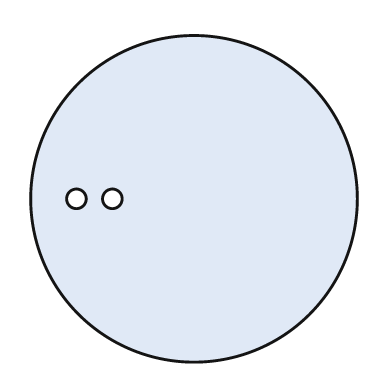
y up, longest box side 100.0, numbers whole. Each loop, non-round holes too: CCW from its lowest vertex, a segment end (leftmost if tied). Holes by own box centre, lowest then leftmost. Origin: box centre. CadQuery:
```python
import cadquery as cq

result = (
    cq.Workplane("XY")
    .moveTo(0.0, 0.0)
    .circle(50.0)
    .moveTo(-36.0, 0.0)
    .circle(3.0)
    .moveTo(-25.0, 0.0)
    .circle(3.0)
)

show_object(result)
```